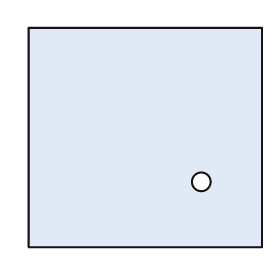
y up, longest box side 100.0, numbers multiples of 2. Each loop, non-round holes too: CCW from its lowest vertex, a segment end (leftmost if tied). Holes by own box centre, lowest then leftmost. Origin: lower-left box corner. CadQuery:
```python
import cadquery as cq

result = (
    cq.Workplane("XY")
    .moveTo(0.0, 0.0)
    .lineTo(100.0, 0.0)
    .lineTo(100.0, 94.0)
    .lineTo(0.0, 94.0)
    .close()
    .moveTo(74.0, 28.0)
    .circle(4.0)
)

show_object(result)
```